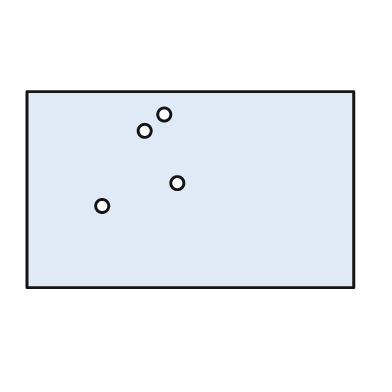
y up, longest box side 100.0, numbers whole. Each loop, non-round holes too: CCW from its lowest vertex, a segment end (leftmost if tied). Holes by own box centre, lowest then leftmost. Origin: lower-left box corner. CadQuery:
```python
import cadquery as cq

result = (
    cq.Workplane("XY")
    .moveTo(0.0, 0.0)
    .lineTo(100.0, 0.0)
    .lineTo(100.0, 60.0)
    .lineTo(0.0, 60.0)
    .close()
    .moveTo(23.0, 25.0)
    .circle(2.0)
    .moveTo(46.0, 32.0)
    .circle(2.0)
    .moveTo(36.0, 48.0)
    .circle(2.0)
    .moveTo(42.0, 53.0)
    .circle(2.0)
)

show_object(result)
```